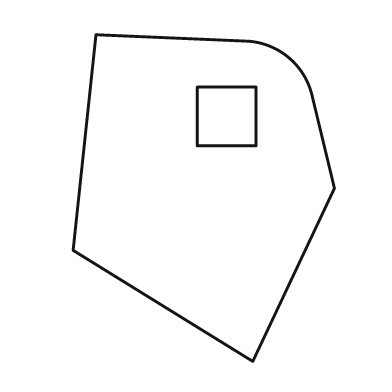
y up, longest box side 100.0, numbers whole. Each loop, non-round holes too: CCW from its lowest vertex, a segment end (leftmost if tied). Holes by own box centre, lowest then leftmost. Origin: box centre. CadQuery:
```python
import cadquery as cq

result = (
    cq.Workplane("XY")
    .moveTo(15.0, -50.0)
    .lineTo(40.0, 3.0)
    .lineTo(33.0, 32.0)
    .threePointArc((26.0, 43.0), (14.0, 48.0))
    .lineTo(-33.0, 50.0)
    .lineTo(-40.0, -16.0)
    .close()
    .moveTo(-2.0, 16.0)
    .lineTo(16.0, 16.0)
    .lineTo(16.0, 34.0)
    .lineTo(-2.0, 34.0)
    .close()
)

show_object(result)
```